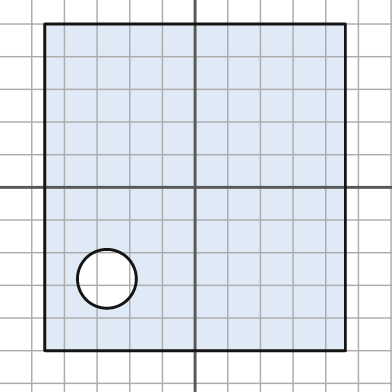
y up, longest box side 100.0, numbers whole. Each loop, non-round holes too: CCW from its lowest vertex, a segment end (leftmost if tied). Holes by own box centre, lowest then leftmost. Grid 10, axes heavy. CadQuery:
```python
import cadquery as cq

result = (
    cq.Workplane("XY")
    .moveTo(-46.0, -50.0)
    .lineTo(46.0, -50.0)
    .lineTo(46.0, 50.0)
    .lineTo(-46.0, 50.0)
    .close()
    .moveTo(-27.0, -28.0)
    .circle(9.0)
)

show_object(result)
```